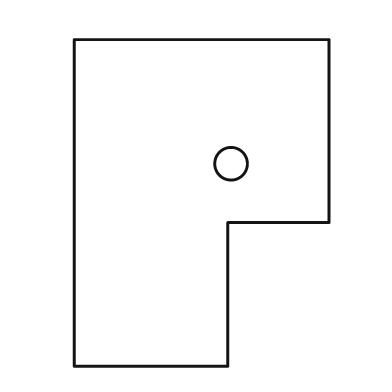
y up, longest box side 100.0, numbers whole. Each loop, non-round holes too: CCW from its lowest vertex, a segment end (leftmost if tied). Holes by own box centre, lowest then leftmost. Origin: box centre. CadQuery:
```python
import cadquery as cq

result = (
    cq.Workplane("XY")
    .moveTo(-39.0, -50.0)
    .lineTo(8.0, -50.0)
    .lineTo(8.0, -6.0)
    .lineTo(39.0, -6.0)
    .lineTo(39.0, 50.0)
    .lineTo(-39.0, 50.0)
    .close()
    .moveTo(9.0, 12.0)
    .circle(5.0)
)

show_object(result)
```